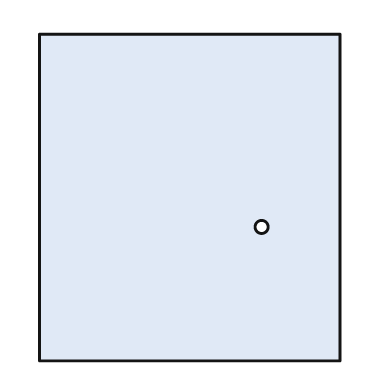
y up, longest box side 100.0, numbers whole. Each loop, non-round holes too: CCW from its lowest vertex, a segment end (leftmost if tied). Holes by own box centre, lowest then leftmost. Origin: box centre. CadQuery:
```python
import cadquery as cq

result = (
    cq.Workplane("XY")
    .moveTo(-46.0, -50.0)
    .lineTo(46.0, -50.0)
    .lineTo(46.0, 50.0)
    .lineTo(-46.0, 50.0)
    .close()
    .moveTo(22.0, -9.0)
    .circle(2.0)
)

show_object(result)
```